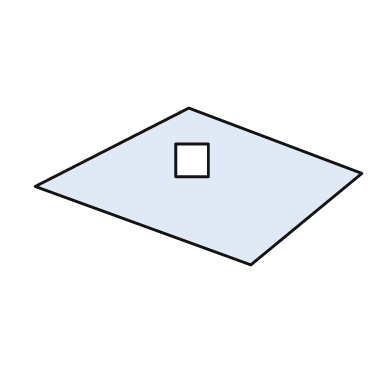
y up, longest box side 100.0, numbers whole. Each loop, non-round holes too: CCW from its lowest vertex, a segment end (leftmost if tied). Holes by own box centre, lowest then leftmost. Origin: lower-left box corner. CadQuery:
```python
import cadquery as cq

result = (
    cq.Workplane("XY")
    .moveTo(66.0, 0.0)
    .lineTo(100.0, 28.0)
    .lineTo(47.0, 48.0)
    .lineTo(0.0, 24.0)
    .close()
    .moveTo(43.0, 27.0)
    .lineTo(53.0, 27.0)
    .lineTo(53.0, 37.0)
    .lineTo(43.0, 37.0)
    .close()
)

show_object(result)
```